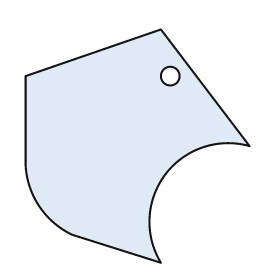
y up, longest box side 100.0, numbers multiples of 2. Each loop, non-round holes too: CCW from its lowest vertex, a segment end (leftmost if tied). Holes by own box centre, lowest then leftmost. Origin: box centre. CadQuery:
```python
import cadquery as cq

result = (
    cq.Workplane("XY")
    .moveTo(10.0, -50.0)
    .threePointArc((12.0, -12.0), (48.0, 0.0))
    .lineTo(10.0, 50.0)
    .lineTo(-48.0, 30.0)
    .lineTo(-48.0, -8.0)
    .threePointArc((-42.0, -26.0), (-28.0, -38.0))
    .close()
    .moveTo(14.0, 30.0)
    .circle(4.0)
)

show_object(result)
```